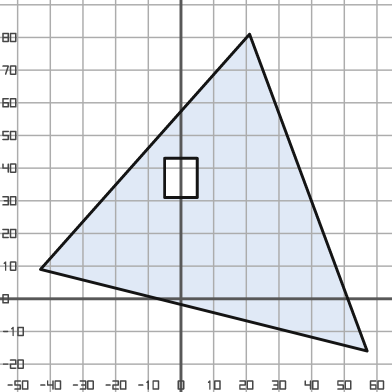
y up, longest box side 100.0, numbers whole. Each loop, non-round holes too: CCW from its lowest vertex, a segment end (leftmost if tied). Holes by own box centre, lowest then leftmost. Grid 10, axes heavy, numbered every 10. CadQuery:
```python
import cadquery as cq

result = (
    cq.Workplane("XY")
    .moveTo(57.0, -16.0)
    .lineTo(21.0, 81.0)
    .lineTo(-43.0, 9.0)
    .close()
    .moveTo(-5.0, 31.0)
    .lineTo(5.0, 31.0)
    .lineTo(5.0, 43.0)
    .lineTo(-5.0, 43.0)
    .close()
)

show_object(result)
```